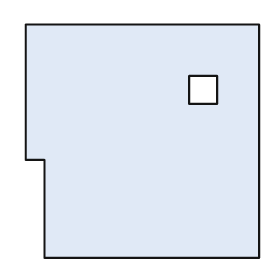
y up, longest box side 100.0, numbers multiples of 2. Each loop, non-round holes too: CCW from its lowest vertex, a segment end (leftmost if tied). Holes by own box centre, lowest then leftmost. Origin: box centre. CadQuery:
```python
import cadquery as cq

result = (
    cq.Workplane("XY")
    .moveTo(-42.0, -50.0)
    .lineTo(50.0, -50.0)
    .lineTo(50.0, 50.0)
    .lineTo(-50.0, 50.0)
    .lineTo(-50.0, -8.0)
    .lineTo(-42.0, -8.0)
    .close()
    .moveTo(20.0, 16.0)
    .lineTo(32.0, 16.0)
    .lineTo(32.0, 28.0)
    .lineTo(20.0, 28.0)
    .close()
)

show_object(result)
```